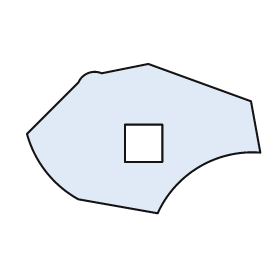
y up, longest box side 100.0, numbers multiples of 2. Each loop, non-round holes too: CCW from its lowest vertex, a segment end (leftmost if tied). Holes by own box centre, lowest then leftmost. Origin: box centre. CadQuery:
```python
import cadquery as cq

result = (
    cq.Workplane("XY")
    .moveTo(6.0, -32.0)
    .threePointArc((24.0, -12.0), (50.0, -6.0))
    .lineTo(46.0, 16.0)
    .lineTo(2.0, 32.0)
    .lineTo(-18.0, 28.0)
    .threePointArc((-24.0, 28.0), (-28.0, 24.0))
    .lineTo(-50.0, 2.0)
    .threePointArc((-42.0, -14.0), (-28.0, -26.0))
    .close()
    .moveTo(-8.0, -10.0)
    .lineTo(8.0, -10.0)
    .lineTo(8.0, 6.0)
    .lineTo(-8.0, 6.0)
    .close()
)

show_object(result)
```